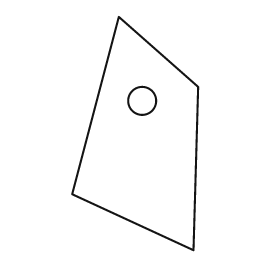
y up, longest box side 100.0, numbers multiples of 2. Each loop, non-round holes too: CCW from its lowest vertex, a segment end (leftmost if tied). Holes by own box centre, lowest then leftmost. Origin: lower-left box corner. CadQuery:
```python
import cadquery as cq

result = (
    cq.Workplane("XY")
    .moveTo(52.0, 0.0)
    .lineTo(54.0, 70.0)
    .lineTo(20.0, 100.0)
    .lineTo(0.0, 24.0)
    .close()
    .moveTo(30.0, 64.0)
    .circle(6.0)
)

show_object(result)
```